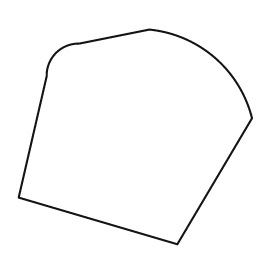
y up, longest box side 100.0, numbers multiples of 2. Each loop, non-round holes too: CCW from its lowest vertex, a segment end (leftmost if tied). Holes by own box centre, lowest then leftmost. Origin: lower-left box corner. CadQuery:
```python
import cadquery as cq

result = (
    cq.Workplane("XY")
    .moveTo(68.0, 0.0)
    .lineTo(100.0, 54.0)
    .threePointArc((84.0, 80.0), (56.0, 92.0))
    .lineTo(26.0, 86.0)
    .threePointArc((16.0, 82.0), (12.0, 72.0))
    .lineTo(0.0, 20.0)
    .close()
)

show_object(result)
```